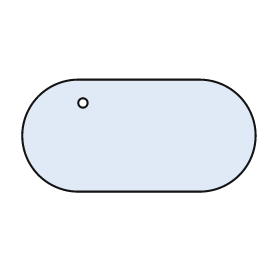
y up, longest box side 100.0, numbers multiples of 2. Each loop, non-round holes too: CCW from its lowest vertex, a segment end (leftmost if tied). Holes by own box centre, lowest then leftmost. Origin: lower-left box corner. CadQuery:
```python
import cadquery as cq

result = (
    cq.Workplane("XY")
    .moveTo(24.0, 0.0)
    .lineTo(76.0, 0.0)
    .threePointArc((100.0, 24.0), (76.0, 48.0))
    .lineTo(24.0, 48.0)
    .threePointArc((0.0, 24.0), (24.0, 0.0))
    .close()
    .moveTo(26.0, 38.0)
    .circle(2.0)
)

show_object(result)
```